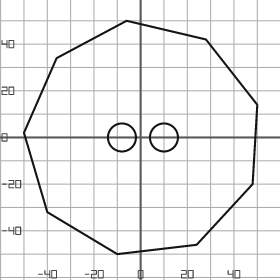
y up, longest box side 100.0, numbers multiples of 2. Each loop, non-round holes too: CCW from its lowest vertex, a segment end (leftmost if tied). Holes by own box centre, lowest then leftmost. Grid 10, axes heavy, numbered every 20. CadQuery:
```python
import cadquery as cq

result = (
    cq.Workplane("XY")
    .moveTo(-10.0, -50.0)
    .lineTo(24.0, -46.0)
    .lineTo(48.0, -20.0)
    .lineTo(50.0, 14.0)
    .lineTo(28.0, 42.0)
    .lineTo(-6.0, 50.0)
    .lineTo(-36.0, 34.0)
    .lineTo(-50.0, 2.0)
    .lineTo(-40.0, -32.0)
    .close()
    .moveTo(-8.0, 0.0)
    .circle(6.0)
    .moveTo(10.0, 0.0)
    .circle(6.0)
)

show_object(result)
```